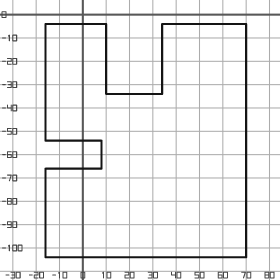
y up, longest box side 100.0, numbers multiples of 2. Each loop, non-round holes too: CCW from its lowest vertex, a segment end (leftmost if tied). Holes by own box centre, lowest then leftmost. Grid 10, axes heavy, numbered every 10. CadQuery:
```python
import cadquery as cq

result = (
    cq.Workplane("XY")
    .moveTo(-16.0, -104.0)
    .lineTo(70.0, -104.0)
    .lineTo(70.0, -4.0)
    .lineTo(34.0, -4.0)
    .lineTo(34.0, -34.0)
    .lineTo(10.0, -34.0)
    .lineTo(10.0, -4.0)
    .lineTo(-16.0, -4.0)
    .lineTo(-16.0, -54.0)
    .lineTo(8.0, -54.0)
    .lineTo(8.0, -66.0)
    .lineTo(-16.0, -66.0)
    .close()
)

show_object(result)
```